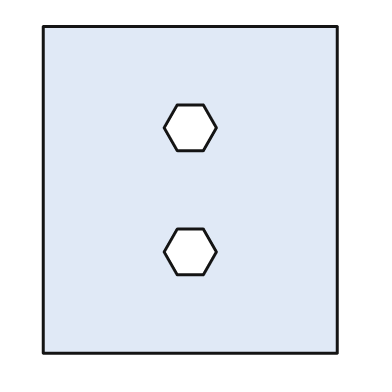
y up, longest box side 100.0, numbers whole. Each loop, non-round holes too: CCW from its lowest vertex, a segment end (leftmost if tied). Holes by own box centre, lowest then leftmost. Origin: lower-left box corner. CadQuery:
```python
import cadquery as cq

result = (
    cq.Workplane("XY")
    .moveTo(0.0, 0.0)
    .lineTo(90.0, 0.0)
    .lineTo(90.0, 100.0)
    .lineTo(0.0, 100.0)
    .close()
    .moveTo(41.0, 24.0)
    .lineTo(49.0, 24.0)
    .lineTo(53.0, 31.0)
    .lineTo(49.0, 38.0)
    .lineTo(41.0, 38.0)
    .lineTo(37.0, 31.0)
    .close()
    .moveTo(41.0, 62.0)
    .lineTo(49.0, 62.0)
    .lineTo(53.0, 69.0)
    .lineTo(49.0, 76.0)
    .lineTo(41.0, 76.0)
    .lineTo(37.0, 69.0)
    .close()
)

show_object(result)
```